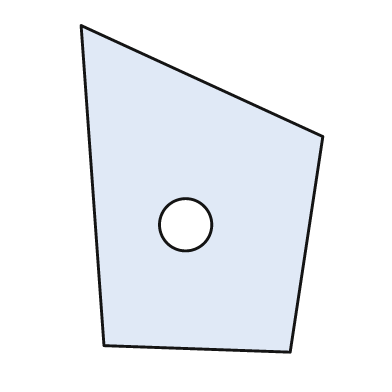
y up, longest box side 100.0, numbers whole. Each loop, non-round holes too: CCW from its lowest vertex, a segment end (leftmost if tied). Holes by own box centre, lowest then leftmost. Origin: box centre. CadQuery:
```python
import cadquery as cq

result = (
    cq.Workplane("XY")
    .moveTo(27.0, -50.0)
    .lineTo(37.0, 16.0)
    .lineTo(-37.0, 50.0)
    .lineTo(-30.0, -48.0)
    .close()
    .moveTo(-5.0, -11.0)
    .circle(8.0)
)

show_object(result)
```